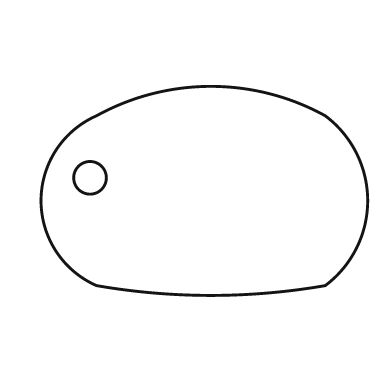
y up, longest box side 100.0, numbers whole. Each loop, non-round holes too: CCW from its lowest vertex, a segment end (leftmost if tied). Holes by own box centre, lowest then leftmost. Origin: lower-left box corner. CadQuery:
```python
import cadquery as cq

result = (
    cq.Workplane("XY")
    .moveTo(17.0, 3.0)
    .threePointArc((52.0, 0.0), (87.0, 3.0))
    .threePointArc((100.0, 29.0), (87.0, 55.0))
    .threePointArc((52.0, 64.0), (17.0, 55.0))
    .threePointArc((0.0, 29.0), (17.0, 3.0))
    .close()
    .moveTo(15.0, 36.0)
    .circle(5.0)
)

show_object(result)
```